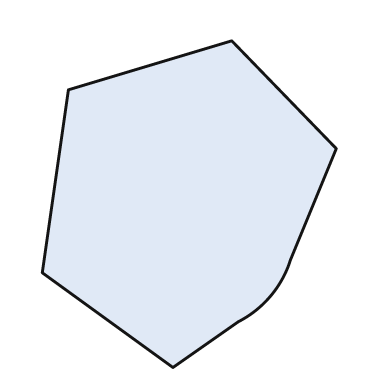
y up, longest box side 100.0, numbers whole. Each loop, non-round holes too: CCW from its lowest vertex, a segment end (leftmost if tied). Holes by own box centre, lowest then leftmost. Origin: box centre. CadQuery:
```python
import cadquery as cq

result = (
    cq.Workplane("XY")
    .moveTo(-5.0, -50.0)
    .lineTo(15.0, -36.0)
    .threePointArc((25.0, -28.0), (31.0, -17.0))
    .lineTo(45.0, 17.0)
    .lineTo(13.0, 50.0)
    .lineTo(-37.0, 35.0)
    .lineTo(-45.0, -21.0)
    .close()
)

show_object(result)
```